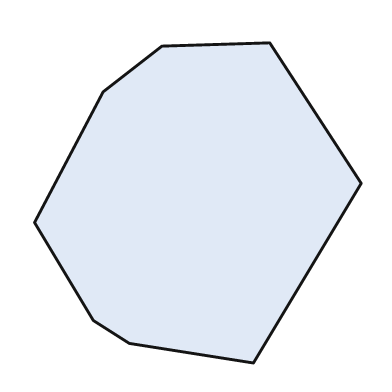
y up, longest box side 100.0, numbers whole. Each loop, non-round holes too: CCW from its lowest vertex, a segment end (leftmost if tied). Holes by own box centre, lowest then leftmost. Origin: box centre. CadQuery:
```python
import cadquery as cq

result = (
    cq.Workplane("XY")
    .moveTo(17.0, -49.0)
    .lineTo(50.0, 6.0)
    .lineTo(22.0, 49.0)
    .lineTo(-11.0, 48.0)
    .lineTo(-29.0, 34.0)
    .lineTo(-50.0, -6.0)
    .lineTo(-32.0, -36.0)
    .lineTo(-21.0, -43.0)
    .close()
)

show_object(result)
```